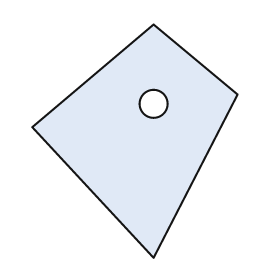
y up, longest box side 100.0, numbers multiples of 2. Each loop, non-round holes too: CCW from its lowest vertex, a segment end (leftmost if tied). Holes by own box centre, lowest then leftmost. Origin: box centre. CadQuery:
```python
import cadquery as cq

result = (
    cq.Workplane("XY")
    .moveTo(8.0, -50.0)
    .lineTo(44.0, 20.0)
    .lineTo(8.0, 50.0)
    .lineTo(-44.0, 6.0)
    .close()
    .moveTo(8.0, 16.0)
    .circle(6.0)
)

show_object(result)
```